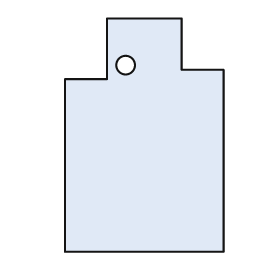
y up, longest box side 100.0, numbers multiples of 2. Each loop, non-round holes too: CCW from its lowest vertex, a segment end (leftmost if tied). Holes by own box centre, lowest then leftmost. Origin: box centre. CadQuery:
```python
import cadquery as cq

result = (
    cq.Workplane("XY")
    .moveTo(-34.0, -50.0)
    .lineTo(34.0, -50.0)
    .lineTo(34.0, 28.0)
    .lineTo(16.0, 28.0)
    .lineTo(16.0, 50.0)
    .lineTo(-16.0, 50.0)
    .lineTo(-16.0, 24.0)
    .lineTo(-34.0, 24.0)
    .close()
    .moveTo(-8.0, 30.0)
    .circle(4.0)
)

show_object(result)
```